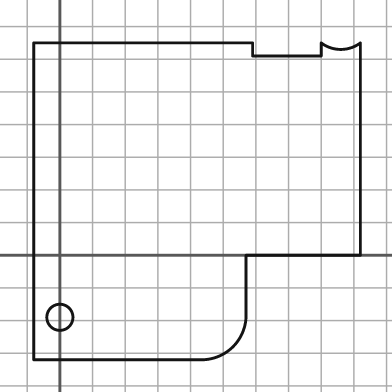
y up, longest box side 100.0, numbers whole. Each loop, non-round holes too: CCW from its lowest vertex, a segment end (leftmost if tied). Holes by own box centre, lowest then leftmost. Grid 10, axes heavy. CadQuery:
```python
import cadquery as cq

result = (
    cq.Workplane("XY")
    .moveTo(-8.0, -32.0)
    .lineTo(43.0, -32.0)
    .threePointArc((53.0, -28.0), (57.0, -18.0))
    .lineTo(57.0, 0.0)
    .lineTo(92.0, 0.0)
    .lineTo(92.0, 65.0)
    .threePointArc((86.0, 63.0), (80.0, 65.0))
    .lineTo(80.0, 61.0)
    .lineTo(59.0, 61.0)
    .lineTo(59.0, 65.0)
    .lineTo(-8.0, 65.0)
    .close()
    .moveTo(0.0, -19.0)
    .circle(4.0)
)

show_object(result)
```